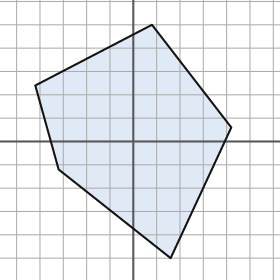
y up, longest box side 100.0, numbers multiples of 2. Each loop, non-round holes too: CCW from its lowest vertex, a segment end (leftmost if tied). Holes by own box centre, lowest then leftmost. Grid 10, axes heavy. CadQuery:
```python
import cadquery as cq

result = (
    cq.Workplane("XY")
    .moveTo(16.0, -50.0)
    .lineTo(42.0, 6.0)
    .lineTo(8.0, 50.0)
    .lineTo(-42.0, 24.0)
    .lineTo(-32.0, -12.0)
    .close()
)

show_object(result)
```